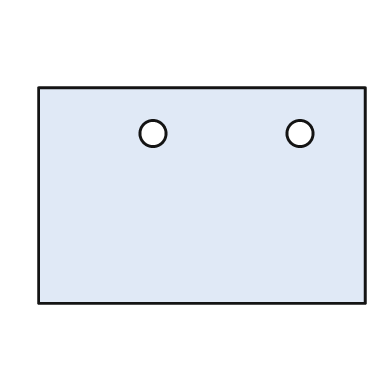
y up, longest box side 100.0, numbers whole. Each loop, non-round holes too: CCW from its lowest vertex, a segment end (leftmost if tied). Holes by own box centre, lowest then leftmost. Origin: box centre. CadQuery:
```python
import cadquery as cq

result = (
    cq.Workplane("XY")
    .moveTo(-50.0, -33.0)
    .lineTo(50.0, -33.0)
    .lineTo(50.0, 33.0)
    .lineTo(-50.0, 33.0)
    .close()
    .moveTo(-15.0, 19.0)
    .circle(4.0)
    .moveTo(30.0, 19.0)
    .circle(4.0)
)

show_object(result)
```